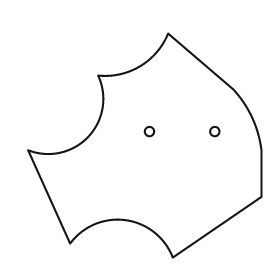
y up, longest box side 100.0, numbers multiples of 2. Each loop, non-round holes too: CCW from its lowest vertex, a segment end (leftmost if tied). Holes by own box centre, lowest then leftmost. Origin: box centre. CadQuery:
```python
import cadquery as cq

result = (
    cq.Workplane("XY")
    .moveTo(12.0, -48.0)
    .lineTo(50.0, -22.0)
    .lineTo(50.0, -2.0)
    .threePointArc((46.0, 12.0), (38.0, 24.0))
    .lineTo(10.0, 48.0)
    .threePointArc((-2.0, 34.0), (-20.0, 30.0))
    .threePointArc((-24.0, 4.0), (-50.0, -2.0))
    .lineTo(-32.0, -42.0)
    .threePointArc((-8.0, -32.0), (12.0, -48.0))
    .close()
    .moveTo(2.0, 6.0)
    .circle(2.0)
    .moveTo(30.0, 6.0)
    .circle(2.0)
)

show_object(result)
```